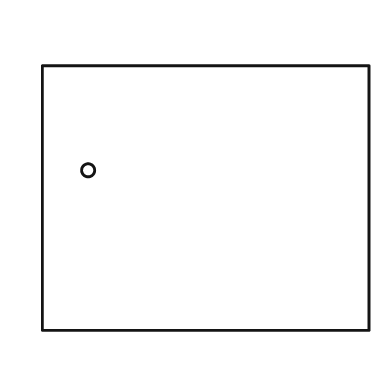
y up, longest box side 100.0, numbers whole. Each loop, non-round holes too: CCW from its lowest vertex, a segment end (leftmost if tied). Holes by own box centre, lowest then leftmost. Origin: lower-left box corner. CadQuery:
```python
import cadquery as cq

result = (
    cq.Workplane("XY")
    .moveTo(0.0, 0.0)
    .lineTo(100.0, 0.0)
    .lineTo(100.0, 81.0)
    .lineTo(0.0, 81.0)
    .close()
    .moveTo(14.0, 49.0)
    .circle(2.0)
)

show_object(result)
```